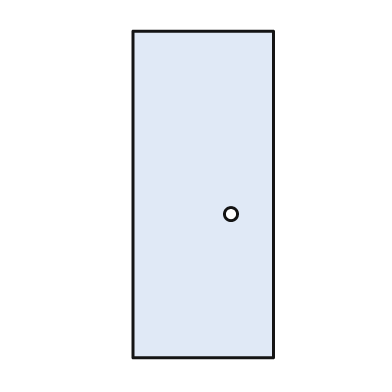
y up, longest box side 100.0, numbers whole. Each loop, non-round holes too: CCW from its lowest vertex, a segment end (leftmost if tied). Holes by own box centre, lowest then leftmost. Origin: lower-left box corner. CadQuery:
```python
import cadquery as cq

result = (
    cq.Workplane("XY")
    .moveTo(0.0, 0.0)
    .lineTo(43.0, 0.0)
    .lineTo(43.0, 100.0)
    .lineTo(0.0, 100.0)
    .close()
    .moveTo(30.0, 44.0)
    .circle(2.0)
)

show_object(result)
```